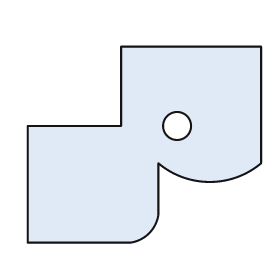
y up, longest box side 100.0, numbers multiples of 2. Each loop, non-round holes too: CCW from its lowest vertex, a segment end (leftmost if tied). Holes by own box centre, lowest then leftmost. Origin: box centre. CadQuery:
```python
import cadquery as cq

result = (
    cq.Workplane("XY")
    .moveTo(-50.0, -42.0)
    .lineTo(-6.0, -42.0)
    .threePointArc((2.0, -38.0), (6.0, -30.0))
    .lineTo(6.0, -8.0)
    .threePointArc((28.0, -16.0), (50.0, -8.0))
    .lineTo(50.0, 42.0)
    .lineTo(-10.0, 42.0)
    .lineTo(-10.0, 8.0)
    .lineTo(-50.0, 8.0)
    .close()
    .moveTo(14.0, 8.0)
    .circle(6.0)
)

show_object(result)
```